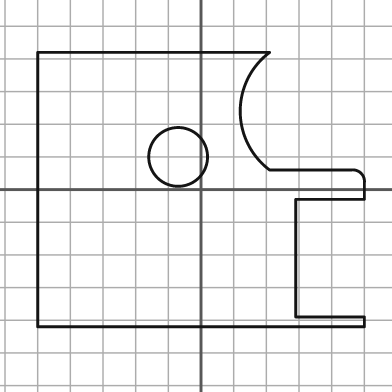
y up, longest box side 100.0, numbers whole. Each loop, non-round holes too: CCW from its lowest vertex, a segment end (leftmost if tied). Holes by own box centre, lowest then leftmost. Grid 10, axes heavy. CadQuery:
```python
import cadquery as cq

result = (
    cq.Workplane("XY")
    .moveTo(-50.0, -42.0)
    .lineTo(50.0, -42.0)
    .lineTo(50.0, -39.0)
    .lineTo(29.0, -39.0)
    .lineTo(29.0, -3.0)
    .lineTo(50.0, -3.0)
    .lineTo(50.0, 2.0)
    .threePointArc((49.0, 5.0), (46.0, 6.0))
    .lineTo(21.0, 6.0)
    .threePointArc((12.0, 24.0), (21.0, 42.0))
    .lineTo(-50.0, 42.0)
    .close()
    .moveTo(-7.0, 10.0)
    .circle(9.0)
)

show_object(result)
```